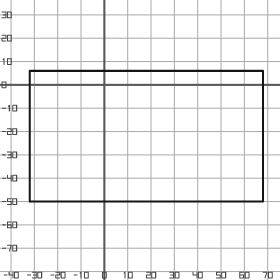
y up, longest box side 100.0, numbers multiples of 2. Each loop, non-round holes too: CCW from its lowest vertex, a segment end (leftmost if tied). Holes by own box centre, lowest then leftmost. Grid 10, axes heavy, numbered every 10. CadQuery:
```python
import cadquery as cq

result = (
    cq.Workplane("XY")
    .moveTo(-32.0, -50.0)
    .lineTo(68.0, -50.0)
    .lineTo(68.0, 6.0)
    .lineTo(-32.0, 6.0)
    .close()
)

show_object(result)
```